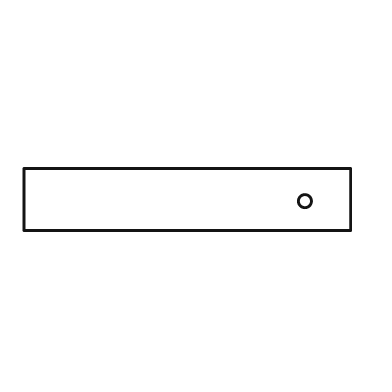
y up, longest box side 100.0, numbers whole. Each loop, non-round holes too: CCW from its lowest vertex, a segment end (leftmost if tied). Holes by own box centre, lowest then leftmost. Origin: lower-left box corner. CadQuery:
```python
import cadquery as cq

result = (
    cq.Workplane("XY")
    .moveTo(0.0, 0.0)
    .lineTo(100.0, 0.0)
    .lineTo(100.0, 19.0)
    .lineTo(0.0, 19.0)
    .close()
    .moveTo(86.0, 9.0)
    .circle(2.0)
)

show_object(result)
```